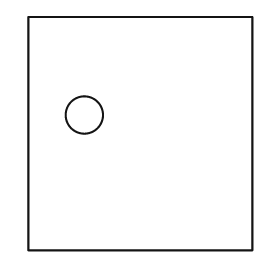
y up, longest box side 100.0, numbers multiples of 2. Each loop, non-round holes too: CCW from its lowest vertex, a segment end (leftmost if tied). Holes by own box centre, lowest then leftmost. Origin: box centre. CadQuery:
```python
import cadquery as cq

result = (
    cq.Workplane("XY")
    .moveTo(-48.0, -50.0)
    .lineTo(48.0, -50.0)
    .lineTo(48.0, 50.0)
    .lineTo(-48.0, 50.0)
    .close()
    .moveTo(-24.0, 8.0)
    .circle(8.0)
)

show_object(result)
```